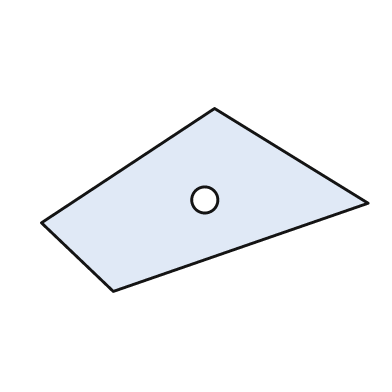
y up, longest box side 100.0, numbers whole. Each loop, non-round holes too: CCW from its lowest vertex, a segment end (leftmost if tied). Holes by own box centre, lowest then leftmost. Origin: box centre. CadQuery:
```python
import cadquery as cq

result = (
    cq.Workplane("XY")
    .moveTo(-28.0, -28.0)
    .lineTo(50.0, -1.0)
    .lineTo(3.0, 28.0)
    .lineTo(-50.0, -7.0)
    .close()
    .moveTo(0.0, 0.0)
    .circle(4.0)
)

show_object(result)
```